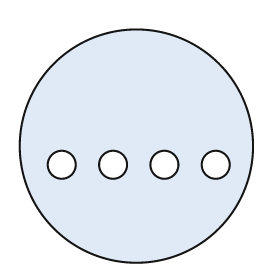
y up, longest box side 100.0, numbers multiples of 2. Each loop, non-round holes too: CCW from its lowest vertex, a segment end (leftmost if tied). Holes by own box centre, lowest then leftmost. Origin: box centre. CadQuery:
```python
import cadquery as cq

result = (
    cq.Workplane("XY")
    .moveTo(0.0, 0.0)
    .circle(50.0)
    .moveTo(-32.0, -8.0)
    .circle(6.0)
    .moveTo(-10.0, -8.0)
    .circle(6.0)
    .moveTo(12.0, -8.0)
    .circle(6.0)
    .moveTo(34.0, -8.0)
    .circle(6.0)
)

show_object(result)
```